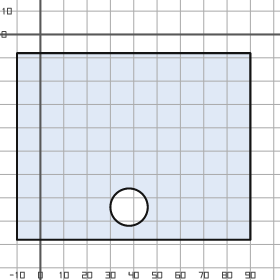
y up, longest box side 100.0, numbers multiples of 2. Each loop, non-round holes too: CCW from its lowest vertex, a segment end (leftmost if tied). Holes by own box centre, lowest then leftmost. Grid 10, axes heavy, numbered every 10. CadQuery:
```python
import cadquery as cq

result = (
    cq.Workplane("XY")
    .moveTo(-10.0, -88.0)
    .lineTo(90.0, -88.0)
    .lineTo(90.0, -8.0)
    .lineTo(-10.0, -8.0)
    .close()
    .moveTo(38.0, -74.0)
    .circle(8.0)
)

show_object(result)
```